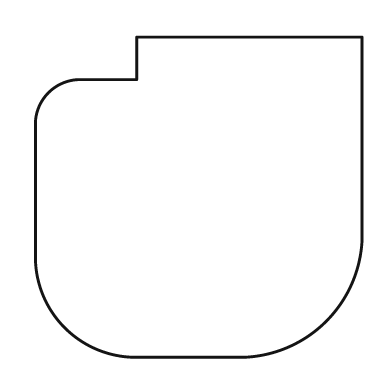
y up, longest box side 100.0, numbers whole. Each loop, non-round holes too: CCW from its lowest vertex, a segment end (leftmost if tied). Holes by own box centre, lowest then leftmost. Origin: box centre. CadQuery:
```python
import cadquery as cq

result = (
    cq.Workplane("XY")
    .moveTo(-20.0, -49.0)
    .lineTo(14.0, -49.0)
    .threePointArc((39.0, -38.0), (50.0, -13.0))
    .lineTo(50.0, 49.0)
    .lineTo(-19.0, 49.0)
    .lineTo(-19.0, 36.0)
    .lineTo(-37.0, 36.0)
    .threePointArc((-46.0, 32.0), (-50.0, 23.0))
    .lineTo(-50.0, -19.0)
    .threePointArc((-41.0, -40.0), (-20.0, -49.0))
    .close()
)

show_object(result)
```